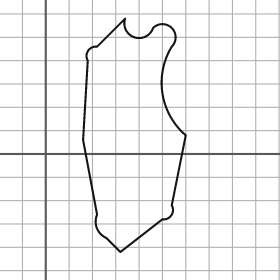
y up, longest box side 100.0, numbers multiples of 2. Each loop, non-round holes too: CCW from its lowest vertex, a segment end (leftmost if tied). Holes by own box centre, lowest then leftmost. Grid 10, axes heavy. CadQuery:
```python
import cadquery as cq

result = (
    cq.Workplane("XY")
    .moveTo(32.0, -42.0)
    .lineTo(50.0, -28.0)
    .threePointArc((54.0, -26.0), (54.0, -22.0))
    .lineTo(60.0, 8.0)
    .threePointArc((50.0, 26.0), (54.0, 46.0))
    .threePointArc((54.0, 54.0), (46.0, 54.0))
    .threePointArc((38.0, 50.0), (34.0, 58.0))
    .lineTo(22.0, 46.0)
    .threePointArc((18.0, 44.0), (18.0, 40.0))
    .lineTo(16.0, 6.0)
    .lineTo(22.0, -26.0)
    .threePointArc((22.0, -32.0), (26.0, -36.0))
    .close()
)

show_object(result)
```